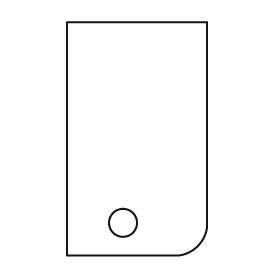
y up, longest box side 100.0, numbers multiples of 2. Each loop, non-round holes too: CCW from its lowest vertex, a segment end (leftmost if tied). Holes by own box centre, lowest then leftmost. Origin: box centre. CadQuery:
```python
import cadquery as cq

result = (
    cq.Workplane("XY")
    .moveTo(-30.0, -50.0)
    .lineTo(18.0, -50.0)
    .threePointArc((26.0, -46.0), (30.0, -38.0))
    .lineTo(30.0, 50.0)
    .lineTo(-30.0, 50.0)
    .close()
    .moveTo(-6.0, -36.0)
    .circle(6.0)
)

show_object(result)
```